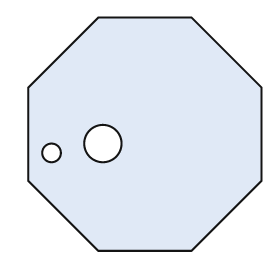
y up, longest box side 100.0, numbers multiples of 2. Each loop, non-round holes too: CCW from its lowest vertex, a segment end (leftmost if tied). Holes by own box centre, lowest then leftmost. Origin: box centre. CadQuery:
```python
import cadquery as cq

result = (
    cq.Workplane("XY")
    .moveTo(-20.0, -50.0)
    .lineTo(20.0, -50.0)
    .lineTo(50.0, -20.0)
    .lineTo(50.0, 20.0)
    .lineTo(20.0, 50.0)
    .lineTo(-20.0, 50.0)
    .lineTo(-50.0, 20.0)
    .lineTo(-50.0, -20.0)
    .close()
    .moveTo(-40.0, -8.0)
    .circle(4.0)
    .moveTo(-18.0, -4.0)
    .circle(8.0)
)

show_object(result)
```